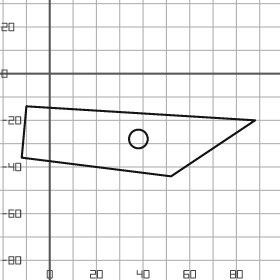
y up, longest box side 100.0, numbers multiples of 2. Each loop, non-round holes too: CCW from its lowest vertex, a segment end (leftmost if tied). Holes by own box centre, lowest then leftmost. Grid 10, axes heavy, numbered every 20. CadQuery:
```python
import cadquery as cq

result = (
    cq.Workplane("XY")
    .moveTo(52.0, -44.0)
    .lineTo(88.0, -20.0)
    .lineTo(-10.0, -14.0)
    .lineTo(-12.0, -36.0)
    .close()
    .moveTo(38.0, -28.0)
    .circle(4.0)
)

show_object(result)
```